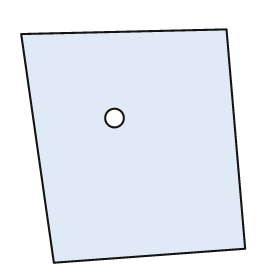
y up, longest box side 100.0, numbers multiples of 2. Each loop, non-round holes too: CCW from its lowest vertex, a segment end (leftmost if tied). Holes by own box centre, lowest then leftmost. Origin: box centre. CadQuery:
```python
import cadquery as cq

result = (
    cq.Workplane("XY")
    .moveTo(-34.0, -50.0)
    .lineTo(48.0, -44.0)
    .lineTo(40.0, 50.0)
    .lineTo(-48.0, 48.0)
    .close()
    .moveTo(-8.0, 12.0)
    .circle(4.0)
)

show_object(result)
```